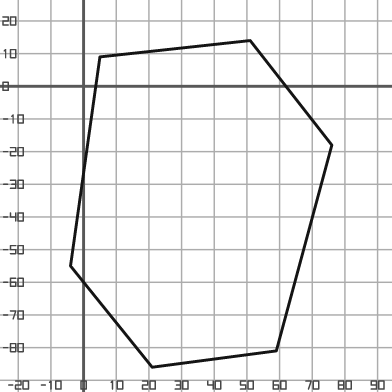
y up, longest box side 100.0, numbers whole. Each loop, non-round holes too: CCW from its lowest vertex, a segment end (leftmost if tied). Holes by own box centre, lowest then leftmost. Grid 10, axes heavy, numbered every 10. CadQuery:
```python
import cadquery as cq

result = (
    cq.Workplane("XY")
    .moveTo(21.0, -86.0)
    .lineTo(59.0, -81.0)
    .lineTo(76.0, -18.0)
    .lineTo(51.0, 14.0)
    .lineTo(5.0, 9.0)
    .lineTo(-4.0, -55.0)
    .close()
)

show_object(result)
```